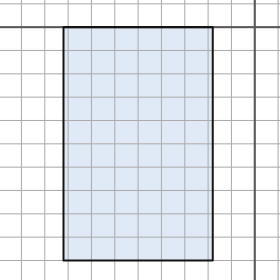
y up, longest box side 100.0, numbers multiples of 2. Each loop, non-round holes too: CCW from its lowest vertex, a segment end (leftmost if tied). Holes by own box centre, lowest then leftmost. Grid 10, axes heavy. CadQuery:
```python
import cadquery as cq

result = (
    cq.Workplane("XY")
    .moveTo(-82.0, -100.0)
    .lineTo(-18.0, -100.0)
    .lineTo(-18.0, 0.0)
    .lineTo(-82.0, 0.0)
    .close()
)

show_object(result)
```